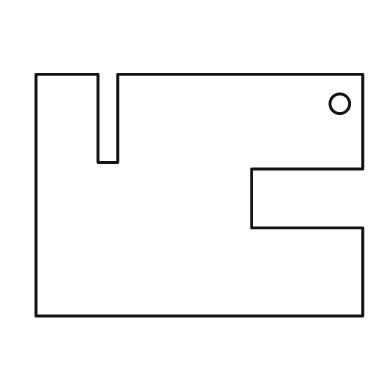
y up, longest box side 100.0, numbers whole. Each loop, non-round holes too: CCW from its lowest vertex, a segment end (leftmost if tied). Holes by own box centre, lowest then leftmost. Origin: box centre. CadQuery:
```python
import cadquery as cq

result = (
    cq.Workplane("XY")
    .moveTo(-50.0, -37.0)
    .lineTo(50.0, -37.0)
    .lineTo(50.0, -10.0)
    .lineTo(16.0, -10.0)
    .lineTo(16.0, 8.0)
    .lineTo(50.0, 8.0)
    .lineTo(50.0, 37.0)
    .lineTo(-25.0, 37.0)
    .lineTo(-25.0, 10.0)
    .lineTo(-31.0, 10.0)
    .lineTo(-31.0, 37.0)
    .lineTo(-50.0, 37.0)
    .close()
    .moveTo(43.0, 28.0)
    .circle(3.0)
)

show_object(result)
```